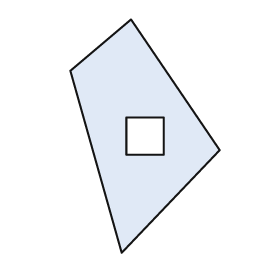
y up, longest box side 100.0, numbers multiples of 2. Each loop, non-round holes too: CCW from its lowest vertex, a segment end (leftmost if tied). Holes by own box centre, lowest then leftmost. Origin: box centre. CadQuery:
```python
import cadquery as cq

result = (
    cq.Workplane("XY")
    .moveTo(-10.0, -50.0)
    .lineTo(32.0, -6.0)
    .lineTo(-6.0, 50.0)
    .lineTo(-32.0, 28.0)
    .close()
    .moveTo(-8.0, -8.0)
    .lineTo(8.0, -8.0)
    .lineTo(8.0, 8.0)
    .lineTo(-8.0, 8.0)
    .close()
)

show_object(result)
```